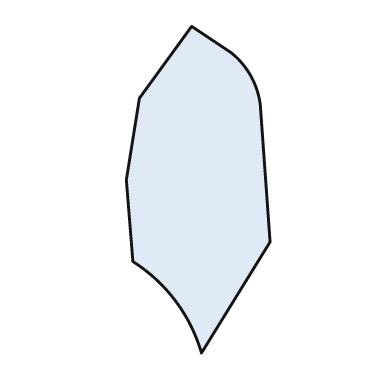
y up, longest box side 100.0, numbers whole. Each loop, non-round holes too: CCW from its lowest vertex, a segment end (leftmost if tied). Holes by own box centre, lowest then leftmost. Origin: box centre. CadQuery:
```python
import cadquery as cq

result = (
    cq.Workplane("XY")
    .moveTo(1.0, -50.0)
    .lineTo(22.0, -16.0)
    .lineTo(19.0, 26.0)
    .threePointArc((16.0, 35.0), (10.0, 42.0))
    .lineTo(-2.0, 50.0)
    .lineTo(-18.0, 28.0)
    .lineTo(-22.0, 3.0)
    .lineTo(-20.0, -22.0)
    .threePointArc((-7.0, -34.0), (1.0, -50.0))
    .close()
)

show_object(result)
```